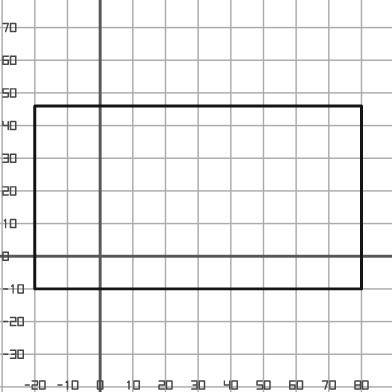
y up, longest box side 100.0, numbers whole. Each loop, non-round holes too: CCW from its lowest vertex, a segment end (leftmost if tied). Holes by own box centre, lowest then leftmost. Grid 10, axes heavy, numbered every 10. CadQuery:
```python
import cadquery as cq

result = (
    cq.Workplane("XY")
    .moveTo(-20.0, -10.0)
    .lineTo(80.0, -10.0)
    .lineTo(80.0, 46.0)
    .lineTo(-20.0, 46.0)
    .close()
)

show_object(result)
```